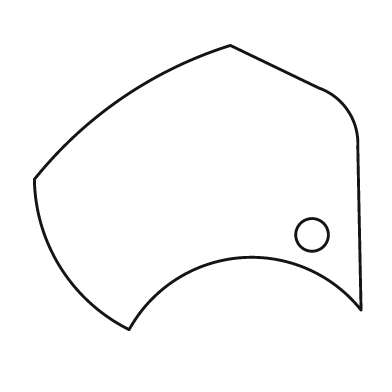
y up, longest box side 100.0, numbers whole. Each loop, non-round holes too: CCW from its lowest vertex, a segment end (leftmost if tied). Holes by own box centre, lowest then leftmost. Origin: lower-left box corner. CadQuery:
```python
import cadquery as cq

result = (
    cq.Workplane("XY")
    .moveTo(29.0, 0.0)
    .threePointArc((63.0, 22.0), (100.0, 6.0))
    .lineTo(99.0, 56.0)
    .threePointArc((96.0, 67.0), (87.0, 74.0))
    .lineTo(60.0, 87.0)
    .threePointArc((27.0, 71.0), (0.0, 46.0))
    .threePointArc((8.0, 19.0), (29.0, 0.0))
    .close()
    .moveTo(85.0, 29.0)
    .circle(5.0)
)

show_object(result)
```